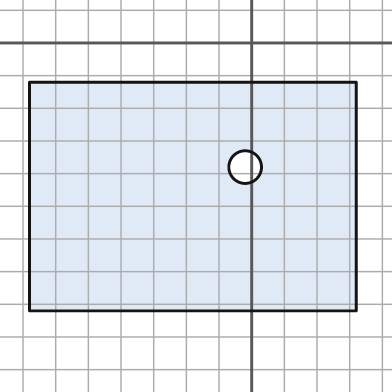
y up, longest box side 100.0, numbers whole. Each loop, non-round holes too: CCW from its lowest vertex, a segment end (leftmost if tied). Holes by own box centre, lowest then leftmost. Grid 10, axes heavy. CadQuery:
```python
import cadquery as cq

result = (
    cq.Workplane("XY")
    .moveTo(-68.0, -82.0)
    .lineTo(32.0, -82.0)
    .lineTo(32.0, -12.0)
    .lineTo(-68.0, -12.0)
    .close()
    .moveTo(-2.0, -38.0)
    .circle(5.0)
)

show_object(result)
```